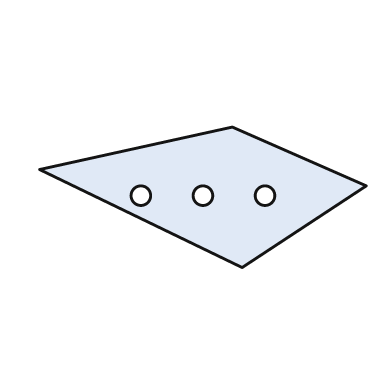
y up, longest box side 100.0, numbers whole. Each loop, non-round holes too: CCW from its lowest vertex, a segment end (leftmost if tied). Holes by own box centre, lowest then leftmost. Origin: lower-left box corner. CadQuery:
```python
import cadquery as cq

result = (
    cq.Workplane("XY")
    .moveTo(62.0, 0.0)
    .lineTo(100.0, 25.0)
    .lineTo(59.0, 43.0)
    .lineTo(0.0, 30.0)
    .close()
    .moveTo(31.0, 22.0)
    .circle(3.0)
    .moveTo(50.0, 22.0)
    .circle(3.0)
    .moveTo(69.0, 22.0)
    .circle(3.0)
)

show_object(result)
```